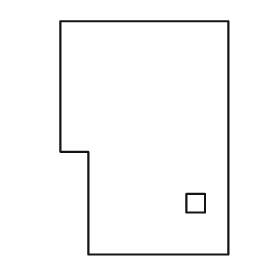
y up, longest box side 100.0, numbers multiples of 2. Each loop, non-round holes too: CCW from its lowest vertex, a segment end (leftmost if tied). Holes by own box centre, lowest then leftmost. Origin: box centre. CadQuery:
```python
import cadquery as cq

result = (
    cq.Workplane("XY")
    .moveTo(-24.0, -50.0)
    .lineTo(36.0, -50.0)
    .lineTo(36.0, 50.0)
    .lineTo(-36.0, 50.0)
    .lineTo(-36.0, -6.0)
    .lineTo(-24.0, -6.0)
    .close()
    .moveTo(18.0, -32.0)
    .lineTo(26.0, -32.0)
    .lineTo(26.0, -24.0)
    .lineTo(18.0, -24.0)
    .close()
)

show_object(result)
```